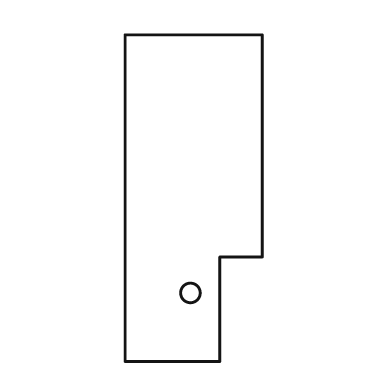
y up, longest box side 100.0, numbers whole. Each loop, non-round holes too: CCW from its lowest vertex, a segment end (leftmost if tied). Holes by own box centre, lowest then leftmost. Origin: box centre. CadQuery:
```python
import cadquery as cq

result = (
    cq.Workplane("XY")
    .moveTo(-21.0, -50.0)
    .lineTo(8.0, -50.0)
    .lineTo(8.0, -18.0)
    .lineTo(21.0, -18.0)
    .lineTo(21.0, 50.0)
    .lineTo(-21.0, 50.0)
    .close()
    .moveTo(-1.0, -29.0)
    .circle(3.0)
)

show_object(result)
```